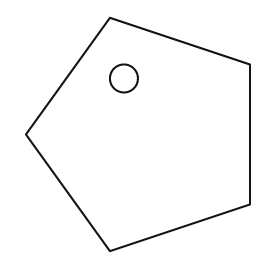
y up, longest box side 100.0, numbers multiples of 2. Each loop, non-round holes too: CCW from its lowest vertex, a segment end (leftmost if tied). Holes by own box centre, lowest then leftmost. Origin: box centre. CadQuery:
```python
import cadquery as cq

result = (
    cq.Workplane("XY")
    .moveTo(-12.0, -50.0)
    .lineTo(48.0, -30.0)
    .lineTo(48.0, 30.0)
    .lineTo(-12.0, 50.0)
    .lineTo(-48.0, 0.0)
    .close()
    .moveTo(-6.0, 24.0)
    .circle(6.0)
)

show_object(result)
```